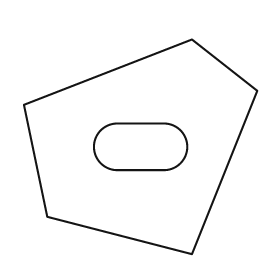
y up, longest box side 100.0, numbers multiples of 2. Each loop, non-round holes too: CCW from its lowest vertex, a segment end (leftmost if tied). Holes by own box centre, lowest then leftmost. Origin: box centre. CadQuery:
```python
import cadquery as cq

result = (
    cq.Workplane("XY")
    .moveTo(22.0, -46.0)
    .lineTo(50.0, 24.0)
    .lineTo(22.0, 46.0)
    .lineTo(-50.0, 18.0)
    .lineTo(-40.0, -30.0)
    .close()
    .moveTo(-10.0, -10.0)
    .lineTo(10.0, -10.0)
    .threePointArc((20.0, 0.0), (10.0, 10.0))
    .lineTo(-10.0, 10.0)
    .threePointArc((-20.0, 0.0), (-10.0, -10.0))
    .close()
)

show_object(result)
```